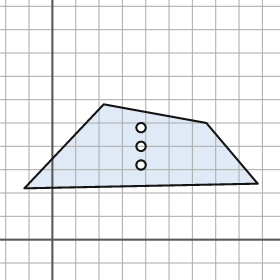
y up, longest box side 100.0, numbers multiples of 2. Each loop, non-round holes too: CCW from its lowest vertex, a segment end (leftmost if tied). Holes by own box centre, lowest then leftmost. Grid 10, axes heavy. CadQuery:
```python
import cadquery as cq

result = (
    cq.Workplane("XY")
    .moveTo(-12.0, 22.0)
    .lineTo(88.0, 24.0)
    .lineTo(66.0, 50.0)
    .lineTo(22.0, 58.0)
    .close()
    .moveTo(38.0, 32.0)
    .circle(2.0)
    .moveTo(38.0, 40.0)
    .circle(2.0)
    .moveTo(38.0, 48.0)
    .circle(2.0)
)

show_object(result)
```